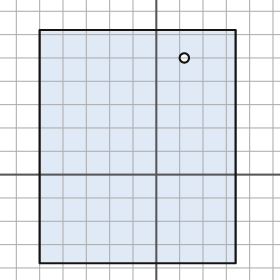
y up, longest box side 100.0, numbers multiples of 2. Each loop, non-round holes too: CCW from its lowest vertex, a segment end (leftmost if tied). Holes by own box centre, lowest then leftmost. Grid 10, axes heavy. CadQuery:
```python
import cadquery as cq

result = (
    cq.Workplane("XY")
    .moveTo(-50.0, -38.0)
    .lineTo(34.0, -38.0)
    .lineTo(34.0, 62.0)
    .lineTo(-50.0, 62.0)
    .close()
    .moveTo(12.0, 50.0)
    .circle(2.0)
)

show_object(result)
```